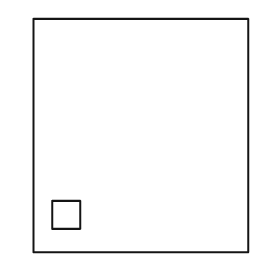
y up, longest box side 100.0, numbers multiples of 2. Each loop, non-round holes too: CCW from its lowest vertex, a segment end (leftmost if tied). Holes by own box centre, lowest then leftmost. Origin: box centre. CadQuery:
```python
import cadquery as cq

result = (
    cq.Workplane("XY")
    .moveTo(-46.0, -50.0)
    .lineTo(46.0, -50.0)
    .lineTo(46.0, 50.0)
    .lineTo(-46.0, 50.0)
    .close()
    .moveTo(-38.0, -40.0)
    .lineTo(-26.0, -40.0)
    .lineTo(-26.0, -28.0)
    .lineTo(-38.0, -28.0)
    .close()
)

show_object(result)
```